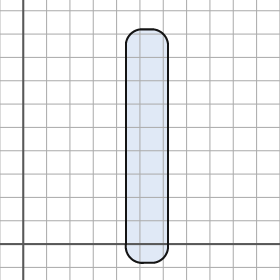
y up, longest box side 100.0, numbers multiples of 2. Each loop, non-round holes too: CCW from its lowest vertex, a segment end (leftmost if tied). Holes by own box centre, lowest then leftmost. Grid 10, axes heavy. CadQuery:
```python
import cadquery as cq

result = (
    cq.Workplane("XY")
    .moveTo(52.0, -8.0)
    .lineTo(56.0, -8.0)
    .threePointArc((60.0, -6.0), (62.0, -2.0))
    .lineTo(62.0, 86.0)
    .threePointArc((60.0, 90.0), (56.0, 92.0))
    .lineTo(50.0, 92.0)
    .threePointArc((46.0, 90.0), (44.0, 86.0))
    .lineTo(44.0, 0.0)
    .threePointArc((46.0, -6.0), (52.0, -8.0))
    .close()
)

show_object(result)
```